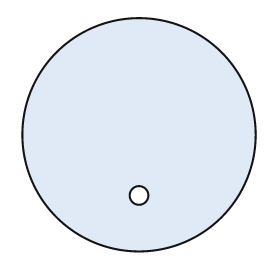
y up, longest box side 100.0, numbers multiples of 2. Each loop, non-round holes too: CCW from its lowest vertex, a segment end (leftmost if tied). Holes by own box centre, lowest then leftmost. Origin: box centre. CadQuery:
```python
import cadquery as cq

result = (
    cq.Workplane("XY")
    .moveTo(0.0, 0.0)
    .circle(50.0)
    .moveTo(0.0, -26.0)
    .circle(4.0)
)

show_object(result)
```